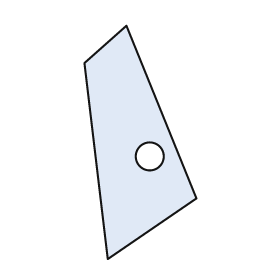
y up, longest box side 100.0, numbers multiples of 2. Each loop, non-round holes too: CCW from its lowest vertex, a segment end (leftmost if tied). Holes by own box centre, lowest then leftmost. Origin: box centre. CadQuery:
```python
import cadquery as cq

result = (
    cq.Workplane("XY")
    .moveTo(-14.0, -50.0)
    .lineTo(24.0, -24.0)
    .lineTo(-6.0, 50.0)
    .lineTo(-24.0, 34.0)
    .close()
    .moveTo(4.0, -6.0)
    .circle(6.0)
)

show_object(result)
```